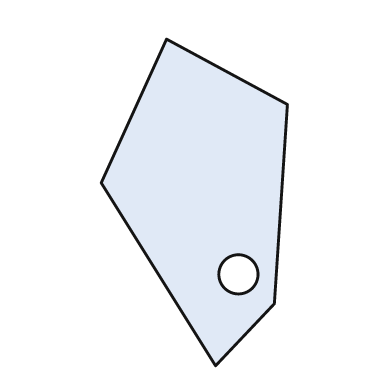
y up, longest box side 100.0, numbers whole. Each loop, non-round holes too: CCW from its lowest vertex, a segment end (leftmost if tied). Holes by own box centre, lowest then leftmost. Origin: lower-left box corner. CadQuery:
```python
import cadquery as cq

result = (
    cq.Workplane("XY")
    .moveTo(35.0, 0.0)
    .lineTo(53.0, 19.0)
    .lineTo(57.0, 80.0)
    .lineTo(20.0, 100.0)
    .lineTo(0.0, 56.0)
    .close()
    .moveTo(42.0, 28.0)
    .circle(6.0)
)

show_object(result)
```